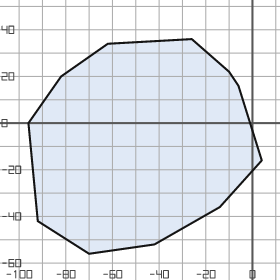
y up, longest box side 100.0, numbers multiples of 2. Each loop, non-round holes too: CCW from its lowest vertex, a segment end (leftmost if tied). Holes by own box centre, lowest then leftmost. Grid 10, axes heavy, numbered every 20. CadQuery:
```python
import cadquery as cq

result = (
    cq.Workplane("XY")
    .moveTo(-70.0, -56.0)
    .lineTo(-42.0, -52.0)
    .lineTo(-14.0, -36.0)
    .lineTo(4.0, -16.0)
    .lineTo(-6.0, 16.0)
    .lineTo(-10.0, 22.0)
    .lineTo(-26.0, 36.0)
    .lineTo(-62.0, 34.0)
    .lineTo(-82.0, 20.0)
    .lineTo(-96.0, 0.0)
    .lineTo(-92.0, -42.0)
    .close()
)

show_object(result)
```